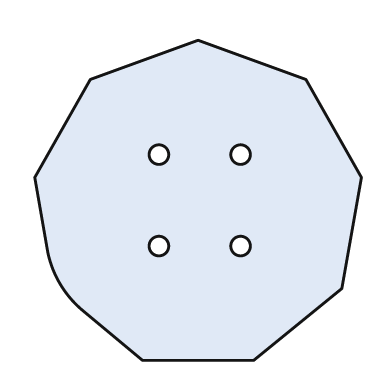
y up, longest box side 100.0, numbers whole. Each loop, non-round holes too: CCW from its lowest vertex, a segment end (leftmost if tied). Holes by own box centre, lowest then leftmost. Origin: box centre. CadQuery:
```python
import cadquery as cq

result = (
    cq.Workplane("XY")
    .moveTo(-17.0, -49.0)
    .lineTo(17.0, -49.0)
    .lineTo(44.0, -27.0)
    .lineTo(50.0, 7.0)
    .lineTo(33.0, 37.0)
    .lineTo(0.0, 49.0)
    .lineTo(-33.0, 37.0)
    .lineTo(-50.0, 7.0)
    .lineTo(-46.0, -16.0)
    .threePointArc((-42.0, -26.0), (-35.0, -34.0))
    .close()
    .moveTo(-12.0, -14.0)
    .circle(3.0)
    .moveTo(13.0, -14.0)
    .circle(3.0)
    .moveTo(-12.0, 14.0)
    .circle(3.0)
    .moveTo(13.0, 14.0)
    .circle(3.0)
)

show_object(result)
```